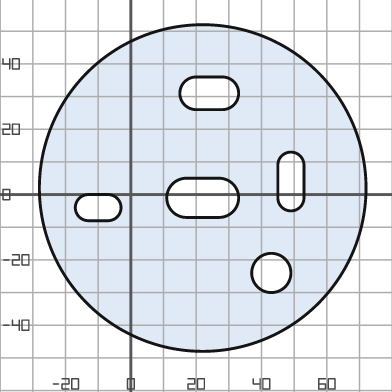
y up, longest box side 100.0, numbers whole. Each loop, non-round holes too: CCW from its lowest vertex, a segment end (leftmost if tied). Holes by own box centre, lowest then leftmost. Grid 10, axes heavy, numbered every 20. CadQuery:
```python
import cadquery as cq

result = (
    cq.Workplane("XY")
    .moveTo(22.0, 2.0)
    .circle(50.0)
    .moveTo(43.0, -24.0)
    .circle(6.0)
    .moveTo(-13.0, -8.0)
    .lineTo(-7.0, -8.0)
    .threePointArc((-3.0, -4.0), (-7.0, 0.0))
    .lineTo(-13.0, 0.0)
    .threePointArc((-17.0, -4.0), (-13.0, -8.0))
    .close()
    .moveTo(17.0, -7.0)
    .lineTo(27.0, -7.0)
    .threePointArc((33.0, -1.0), (27.0, 5.0))
    .lineTo(17.0, 5.0)
    .threePointArc((11.0, -1.0), (17.0, -7.0))
    .close()
    .moveTo(45.0, -1.0)
    .threePointArc((49.0, -5.0), (53.0, -1.0))
    .lineTo(53.0, 9.0)
    .threePointArc((49.0, 13.0), (45.0, 9.0))
    .close()
    .moveTo(20.0, 26.0)
    .lineTo(28.0, 26.0)
    .threePointArc((33.0, 31.0), (28.0, 36.0))
    .lineTo(20.0, 36.0)
    .threePointArc((15.0, 31.0), (20.0, 26.0))
    .close()
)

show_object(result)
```